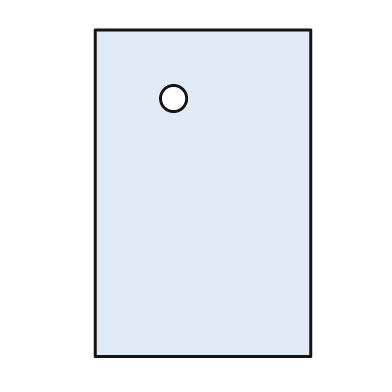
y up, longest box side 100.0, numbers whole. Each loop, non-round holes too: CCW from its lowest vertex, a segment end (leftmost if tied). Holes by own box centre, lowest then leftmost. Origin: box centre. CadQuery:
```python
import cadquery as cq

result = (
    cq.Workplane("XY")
    .moveTo(-33.0, -50.0)
    .lineTo(33.0, -50.0)
    .lineTo(33.0, 50.0)
    .lineTo(-33.0, 50.0)
    .close()
    .moveTo(-9.0, 29.0)
    .circle(4.0)
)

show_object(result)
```